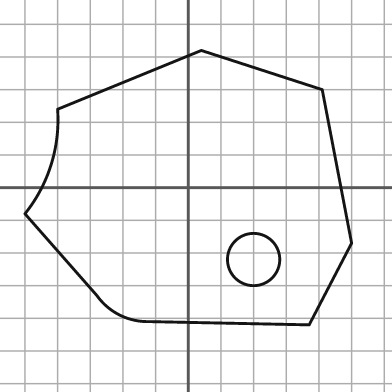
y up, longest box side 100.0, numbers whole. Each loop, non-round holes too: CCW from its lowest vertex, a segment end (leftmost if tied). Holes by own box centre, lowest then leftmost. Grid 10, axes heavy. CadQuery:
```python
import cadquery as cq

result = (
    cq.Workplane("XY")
    .moveTo(37.0, -42.0)
    .lineTo(50.0, -17.0)
    .lineTo(41.0, 30.0)
    .lineTo(4.0, 42.0)
    .lineTo(-40.0, 24.0)
    .threePointArc((-42.0, 7.0), (-50.0, -8.0))
    .lineTo(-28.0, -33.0)
    .threePointArc((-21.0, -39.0), (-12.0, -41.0))
    .close()
    .moveTo(20.0, -22.0)
    .circle(8.0)
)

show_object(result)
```